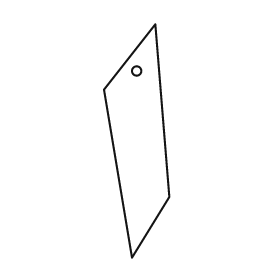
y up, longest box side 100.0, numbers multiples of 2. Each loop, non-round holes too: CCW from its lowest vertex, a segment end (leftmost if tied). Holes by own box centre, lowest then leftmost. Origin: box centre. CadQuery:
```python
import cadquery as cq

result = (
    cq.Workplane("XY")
    .moveTo(-2.0, -50.0)
    .lineTo(14.0, -24.0)
    .lineTo(8.0, 50.0)
    .lineTo(-14.0, 22.0)
    .close()
    .moveTo(0.0, 30.0)
    .circle(2.0)
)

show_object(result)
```